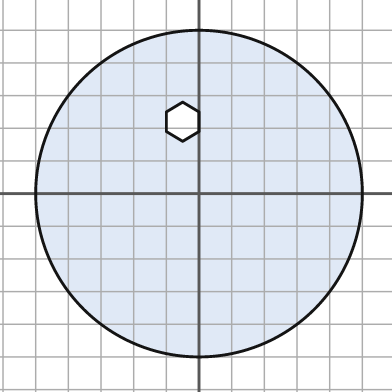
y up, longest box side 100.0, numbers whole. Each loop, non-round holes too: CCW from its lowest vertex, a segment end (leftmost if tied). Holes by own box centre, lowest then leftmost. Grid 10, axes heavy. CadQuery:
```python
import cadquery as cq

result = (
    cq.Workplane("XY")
    .moveTo(0.0, 0.0)
    .circle(50.0)
    .moveTo(-5.0, 16.0)
    .lineTo(0.0, 19.0)
    .lineTo(0.0, 25.0)
    .lineTo(-5.0, 28.0)
    .lineTo(-10.0, 25.0)
    .lineTo(-10.0, 19.0)
    .close()
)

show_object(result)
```